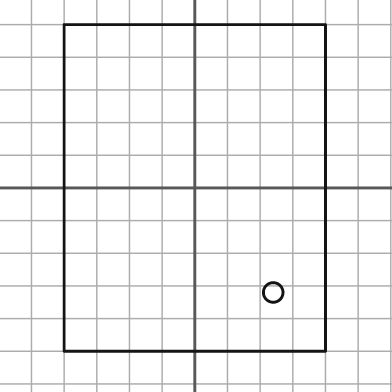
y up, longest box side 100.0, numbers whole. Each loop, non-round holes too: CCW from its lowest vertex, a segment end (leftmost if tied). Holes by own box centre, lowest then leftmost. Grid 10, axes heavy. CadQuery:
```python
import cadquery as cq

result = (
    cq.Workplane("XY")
    .moveTo(-40.0, -50.0)
    .lineTo(40.0, -50.0)
    .lineTo(40.0, 50.0)
    .lineTo(-40.0, 50.0)
    .close()
    .moveTo(24.0, -32.0)
    .circle(3.0)
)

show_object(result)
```